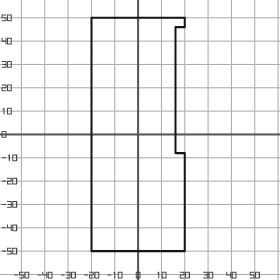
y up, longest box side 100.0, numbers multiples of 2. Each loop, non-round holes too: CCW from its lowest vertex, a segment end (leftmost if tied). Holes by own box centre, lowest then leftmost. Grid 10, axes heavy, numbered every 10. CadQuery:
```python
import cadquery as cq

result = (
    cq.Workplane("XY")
    .moveTo(-20.0, -50.0)
    .lineTo(20.0, -50.0)
    .lineTo(20.0, -8.0)
    .lineTo(16.0, -8.0)
    .lineTo(16.0, 46.0)
    .lineTo(20.0, 46.0)
    .lineTo(20.0, 50.0)
    .lineTo(-20.0, 50.0)
    .close()
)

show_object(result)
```